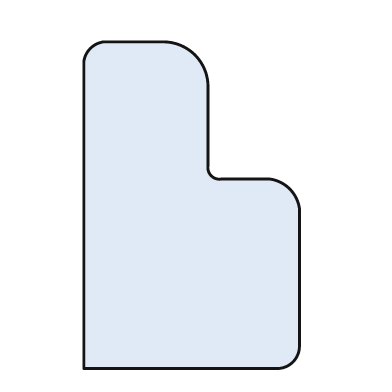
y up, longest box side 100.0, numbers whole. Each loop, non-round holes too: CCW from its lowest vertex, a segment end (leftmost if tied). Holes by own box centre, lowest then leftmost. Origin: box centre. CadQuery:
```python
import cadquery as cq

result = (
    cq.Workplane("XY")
    .moveTo(-33.0, -50.0)
    .lineTo(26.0, -50.0)
    .threePointArc((31.0, -48.0), (33.0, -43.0))
    .lineTo(33.0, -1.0)
    .threePointArc((30.0, 5.0), (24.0, 8.0))
    .lineTo(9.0, 8.0)
    .threePointArc((6.0, 9.0), (5.0, 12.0))
    .lineTo(5.0, 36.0)
    .threePointArc((1.0, 46.0), (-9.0, 50.0))
    .lineTo(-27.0, 50.0)
    .threePointArc((-31.0, 48.0), (-33.0, 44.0))
    .close()
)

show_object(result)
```